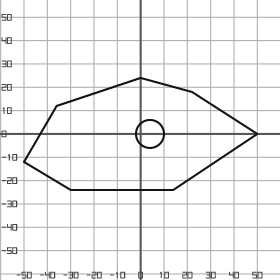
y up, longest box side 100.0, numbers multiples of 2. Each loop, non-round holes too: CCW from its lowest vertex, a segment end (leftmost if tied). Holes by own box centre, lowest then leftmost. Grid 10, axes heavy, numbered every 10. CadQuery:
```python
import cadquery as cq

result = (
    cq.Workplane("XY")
    .moveTo(-30.0, -24.0)
    .lineTo(14.0, -24.0)
    .lineTo(50.0, 0.0)
    .lineTo(22.0, 18.0)
    .lineTo(0.0, 24.0)
    .lineTo(-36.0, 12.0)
    .lineTo(-50.0, -12.0)
    .close()
    .moveTo(4.0, 0.0)
    .circle(6.0)
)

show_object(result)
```